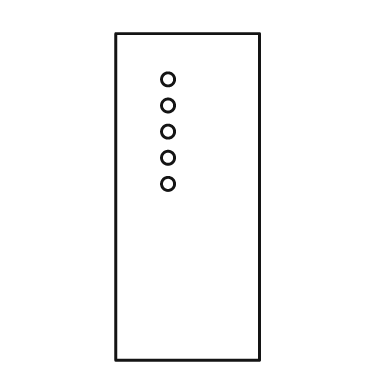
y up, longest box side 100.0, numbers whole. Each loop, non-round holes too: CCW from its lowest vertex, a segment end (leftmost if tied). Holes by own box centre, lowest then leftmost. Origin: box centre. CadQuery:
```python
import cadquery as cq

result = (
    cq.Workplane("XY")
    .moveTo(-22.0, -50.0)
    .lineTo(22.0, -50.0)
    .lineTo(22.0, 50.0)
    .lineTo(-22.0, 50.0)
    .close()
    .moveTo(-6.0, 4.0)
    .circle(2.0)
    .moveTo(-6.0, 12.0)
    .circle(2.0)
    .moveTo(-6.0, 20.0)
    .circle(2.0)
    .moveTo(-6.0, 28.0)
    .circle(2.0)
    .moveTo(-6.0, 36.0)
    .circle(2.0)
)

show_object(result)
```